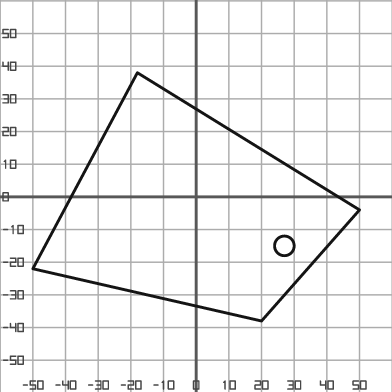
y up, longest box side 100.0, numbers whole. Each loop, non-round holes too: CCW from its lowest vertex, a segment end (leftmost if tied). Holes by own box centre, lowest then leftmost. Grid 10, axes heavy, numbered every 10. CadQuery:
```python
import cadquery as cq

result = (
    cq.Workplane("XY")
    .moveTo(20.0, -38.0)
    .lineTo(50.0, -4.0)
    .lineTo(-18.0, 38.0)
    .lineTo(-50.0, -22.0)
    .close()
    .moveTo(27.0, -15.0)
    .circle(3.0)
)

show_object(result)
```